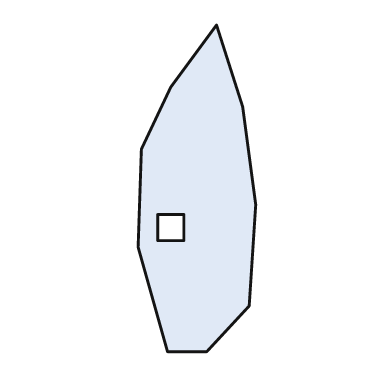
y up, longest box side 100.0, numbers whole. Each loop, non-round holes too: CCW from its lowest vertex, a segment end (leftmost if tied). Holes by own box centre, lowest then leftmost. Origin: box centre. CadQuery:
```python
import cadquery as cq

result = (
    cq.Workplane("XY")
    .moveTo(-9.0, -50.0)
    .lineTo(3.0, -50.0)
    .lineTo(16.0, -36.0)
    .lineTo(18.0, -5.0)
    .lineTo(14.0, 25.0)
    .lineTo(6.0, 50.0)
    .lineTo(-8.0, 31.0)
    .lineTo(-17.0, 12.0)
    .lineTo(-18.0, -18.0)
    .close()
    .moveTo(-12.0, -16.0)
    .lineTo(-4.0, -16.0)
    .lineTo(-4.0, -8.0)
    .lineTo(-12.0, -8.0)
    .close()
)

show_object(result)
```